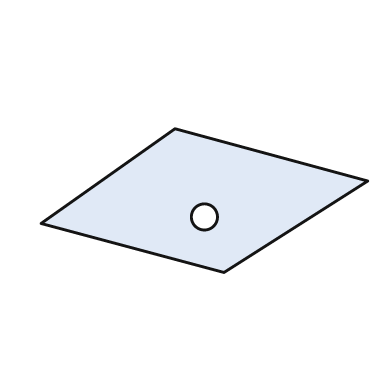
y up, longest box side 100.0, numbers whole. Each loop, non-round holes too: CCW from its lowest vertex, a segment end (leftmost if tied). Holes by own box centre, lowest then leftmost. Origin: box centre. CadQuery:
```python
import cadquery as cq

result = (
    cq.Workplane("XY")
    .moveTo(6.0, -22.0)
    .lineTo(50.0, 6.0)
    .lineTo(-9.0, 22.0)
    .lineTo(-50.0, -7.0)
    .close()
    .moveTo(0.0, -5.0)
    .circle(4.0)
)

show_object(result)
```